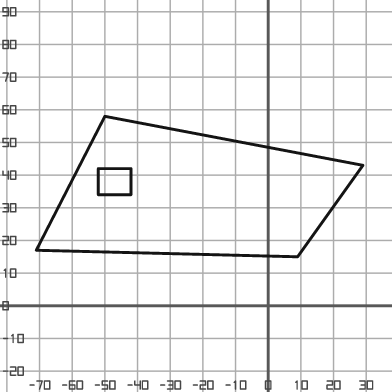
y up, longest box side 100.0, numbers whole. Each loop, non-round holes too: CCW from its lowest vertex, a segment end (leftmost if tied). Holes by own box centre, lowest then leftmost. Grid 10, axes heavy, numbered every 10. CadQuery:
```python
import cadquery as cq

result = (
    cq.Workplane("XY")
    .moveTo(9.0, 15.0)
    .lineTo(29.0, 43.0)
    .lineTo(-50.0, 58.0)
    .lineTo(-71.0, 17.0)
    .close()
    .moveTo(-52.0, 34.0)
    .lineTo(-42.0, 34.0)
    .lineTo(-42.0, 42.0)
    .lineTo(-52.0, 42.0)
    .close()
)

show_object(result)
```